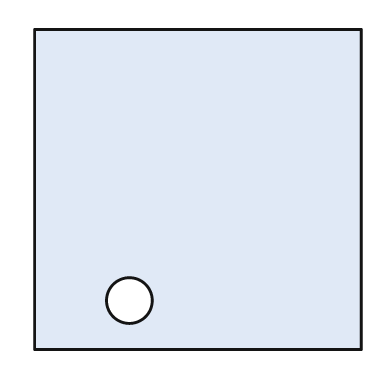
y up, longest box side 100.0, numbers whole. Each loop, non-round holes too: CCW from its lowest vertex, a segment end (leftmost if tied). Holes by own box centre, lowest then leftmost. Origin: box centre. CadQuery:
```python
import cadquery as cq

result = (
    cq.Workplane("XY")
    .moveTo(-50.0, -49.0)
    .lineTo(50.0, -49.0)
    .lineTo(50.0, 49.0)
    .lineTo(-50.0, 49.0)
    .close()
    .moveTo(-21.0, -34.0)
    .circle(7.0)
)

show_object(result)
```